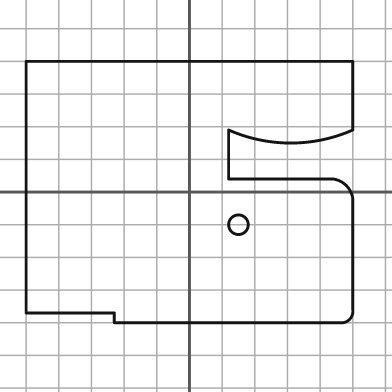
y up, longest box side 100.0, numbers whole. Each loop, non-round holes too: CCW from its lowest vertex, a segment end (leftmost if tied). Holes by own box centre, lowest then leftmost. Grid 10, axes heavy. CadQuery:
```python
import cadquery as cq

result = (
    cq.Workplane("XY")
    .moveTo(-23.0, -40.0)
    .lineTo(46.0, -40.0)
    .threePointArc((49.0, -39.0), (50.0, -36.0))
    .lineTo(50.0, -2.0)
    .threePointArc((48.0, 2.0), (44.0, 4.0))
    .lineTo(12.0, 4.0)
    .lineTo(12.0, 19.0)
    .threePointArc((31.0, 15.0), (50.0, 19.0))
    .lineTo(50.0, 40.0)
    .lineTo(-50.0, 40.0)
    .lineTo(-50.0, -37.0)
    .lineTo(-23.0, -37.0)
    .close()
    .moveTo(15.0, -10.0)
    .circle(3.0)
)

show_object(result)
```